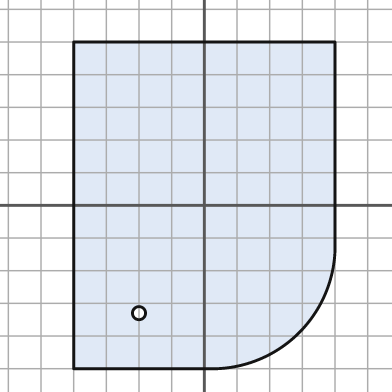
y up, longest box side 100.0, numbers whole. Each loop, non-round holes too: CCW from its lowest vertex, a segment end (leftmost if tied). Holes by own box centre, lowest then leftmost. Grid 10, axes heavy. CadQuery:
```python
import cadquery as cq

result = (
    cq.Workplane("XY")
    .moveTo(-40.0, -50.0)
    .lineTo(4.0, -50.0)
    .threePointArc((29.0, -39.0), (40.0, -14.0))
    .lineTo(40.0, 50.0)
    .lineTo(-40.0, 50.0)
    .close()
    .moveTo(-20.0, -33.0)
    .circle(2.0)
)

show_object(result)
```